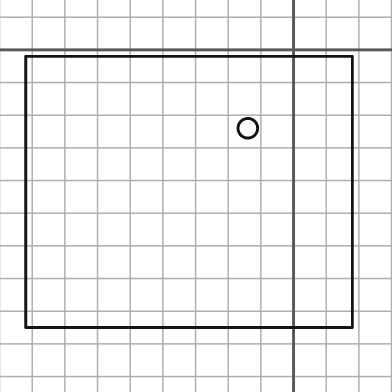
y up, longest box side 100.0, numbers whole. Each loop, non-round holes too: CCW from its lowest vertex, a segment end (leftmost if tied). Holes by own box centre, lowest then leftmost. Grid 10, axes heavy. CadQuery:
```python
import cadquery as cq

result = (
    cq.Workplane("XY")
    .moveTo(-82.0, -85.0)
    .lineTo(18.0, -85.0)
    .lineTo(18.0, -2.0)
    .lineTo(-82.0, -2.0)
    .close()
    .moveTo(-14.0, -24.0)
    .circle(3.0)
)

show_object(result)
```